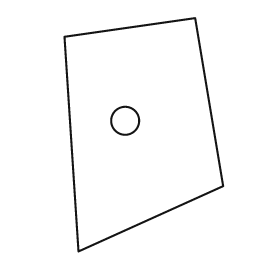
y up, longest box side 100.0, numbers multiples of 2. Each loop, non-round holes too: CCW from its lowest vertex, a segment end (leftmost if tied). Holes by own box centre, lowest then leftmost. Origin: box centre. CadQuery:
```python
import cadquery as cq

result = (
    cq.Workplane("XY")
    .moveTo(-28.0, -50.0)
    .lineTo(34.0, -22.0)
    .lineTo(22.0, 50.0)
    .lineTo(-34.0, 42.0)
    .close()
    .moveTo(-8.0, 6.0)
    .circle(6.0)
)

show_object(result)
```